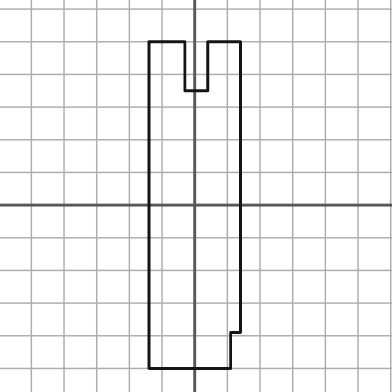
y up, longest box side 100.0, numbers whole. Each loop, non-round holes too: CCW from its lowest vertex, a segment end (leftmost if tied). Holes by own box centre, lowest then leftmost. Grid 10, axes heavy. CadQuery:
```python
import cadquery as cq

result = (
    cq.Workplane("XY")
    .moveTo(-14.0, -50.0)
    .lineTo(11.0, -50.0)
    .lineTo(11.0, -39.0)
    .lineTo(14.0, -39.0)
    .lineTo(14.0, 50.0)
    .lineTo(4.0, 50.0)
    .lineTo(4.0, 35.0)
    .lineTo(-3.0, 35.0)
    .lineTo(-3.0, 50.0)
    .lineTo(-14.0, 50.0)
    .close()
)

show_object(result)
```